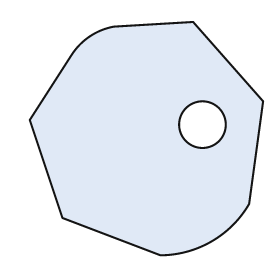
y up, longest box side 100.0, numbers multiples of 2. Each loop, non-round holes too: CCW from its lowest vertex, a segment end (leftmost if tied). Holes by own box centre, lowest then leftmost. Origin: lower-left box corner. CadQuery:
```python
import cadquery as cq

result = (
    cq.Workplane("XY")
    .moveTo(56.0, 0.0)
    .threePointArc((78.0, 6.0), (94.0, 22.0))
    .lineTo(100.0, 66.0)
    .lineTo(70.0, 100.0)
    .lineTo(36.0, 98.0)
    .threePointArc((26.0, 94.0), (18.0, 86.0))
    .lineTo(0.0, 58.0)
    .lineTo(14.0, 16.0)
    .close()
    .moveTo(74.0, 56.0)
    .circle(10.0)
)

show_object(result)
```